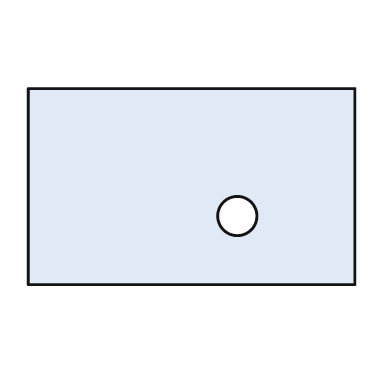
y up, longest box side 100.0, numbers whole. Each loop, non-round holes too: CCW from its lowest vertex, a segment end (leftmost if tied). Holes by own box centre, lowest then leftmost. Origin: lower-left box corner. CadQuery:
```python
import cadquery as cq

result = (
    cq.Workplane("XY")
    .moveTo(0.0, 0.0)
    .lineTo(100.0, 0.0)
    .lineTo(100.0, 60.0)
    .lineTo(0.0, 60.0)
    .close()
    .moveTo(64.0, 21.0)
    .circle(6.0)
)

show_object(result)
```